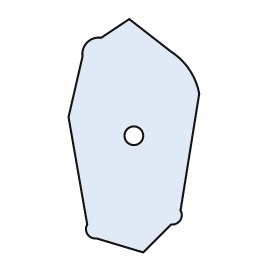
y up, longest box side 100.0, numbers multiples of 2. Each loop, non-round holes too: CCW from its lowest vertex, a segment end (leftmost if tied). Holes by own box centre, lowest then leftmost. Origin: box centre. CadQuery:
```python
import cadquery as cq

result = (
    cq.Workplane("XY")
    .moveTo(4.0, -50.0)
    .lineTo(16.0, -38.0)
    .threePointArc((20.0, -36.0), (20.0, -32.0))
    .lineTo(28.0, 18.0)
    .threePointArc((24.0, 28.0), (16.0, 36.0))
    .lineTo(-2.0, 50.0)
    .lineTo(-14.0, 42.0)
    .threePointArc((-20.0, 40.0), (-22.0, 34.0))
    .lineTo(-28.0, 8.0)
    .lineTo(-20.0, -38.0)
    .threePointArc((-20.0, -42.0), (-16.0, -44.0))
    .close()
    .moveTo(0.0, 0.0)
    .circle(4.0)
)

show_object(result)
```